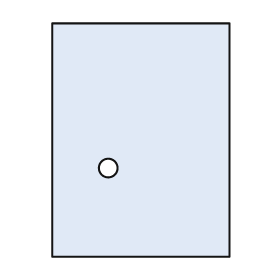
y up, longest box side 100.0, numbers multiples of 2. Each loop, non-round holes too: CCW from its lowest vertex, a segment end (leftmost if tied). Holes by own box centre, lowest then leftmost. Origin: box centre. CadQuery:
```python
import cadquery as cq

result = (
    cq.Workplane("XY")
    .moveTo(-38.0, -50.0)
    .lineTo(38.0, -50.0)
    .lineTo(38.0, 50.0)
    .lineTo(-38.0, 50.0)
    .close()
    .moveTo(-14.0, -12.0)
    .circle(4.0)
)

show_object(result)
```